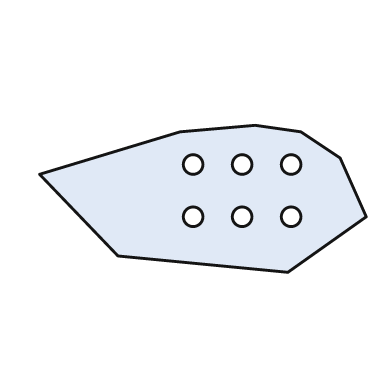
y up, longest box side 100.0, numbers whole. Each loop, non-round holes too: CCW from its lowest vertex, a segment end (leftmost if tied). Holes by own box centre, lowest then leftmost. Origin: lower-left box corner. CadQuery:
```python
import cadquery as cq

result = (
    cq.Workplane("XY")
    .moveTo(76.0, 0.0)
    .lineTo(100.0, 17.0)
    .lineTo(92.0, 35.0)
    .lineTo(80.0, 43.0)
    .lineTo(66.0, 45.0)
    .lineTo(43.0, 43.0)
    .lineTo(0.0, 30.0)
    .lineTo(24.0, 5.0)
    .close()
    .moveTo(47.0, 17.0)
    .circle(3.0)
    .moveTo(62.0, 17.0)
    .circle(3.0)
    .moveTo(77.0, 17.0)
    .circle(3.0)
    .moveTo(47.0, 33.0)
    .circle(3.0)
    .moveTo(62.0, 33.0)
    .circle(3.0)
    .moveTo(77.0, 33.0)
    .circle(3.0)
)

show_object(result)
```